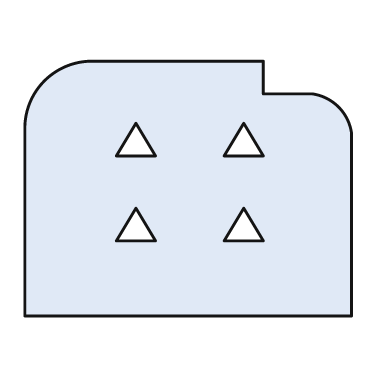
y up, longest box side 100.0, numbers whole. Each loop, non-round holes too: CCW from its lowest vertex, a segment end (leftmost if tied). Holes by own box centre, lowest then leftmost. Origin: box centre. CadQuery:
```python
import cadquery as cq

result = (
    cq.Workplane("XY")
    .moveTo(-50.0, -39.0)
    .lineTo(50.0, -39.0)
    .lineTo(50.0, 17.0)
    .threePointArc((46.0, 25.0), (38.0, 29.0))
    .lineTo(23.0, 29.0)
    .lineTo(23.0, 39.0)
    .lineTo(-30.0, 39.0)
    .threePointArc((-44.0, 33.0), (-50.0, 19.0))
    .close()
    .moveTo(-22.0, -16.0)
    .lineTo(-10.0, -16.0)
    .lineTo(-16.0, -6.0)
    .close()
    .moveTo(11.0, -16.0)
    .lineTo(23.0, -16.0)
    .lineTo(17.0, -6.0)
    .close()
    .moveTo(-22.0, 10.0)
    .lineTo(-10.0, 10.0)
    .lineTo(-16.0, 20.0)
    .close()
    .moveTo(11.0, 10.0)
    .lineTo(23.0, 10.0)
    .lineTo(17.0, 20.0)
    .close()
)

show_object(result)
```